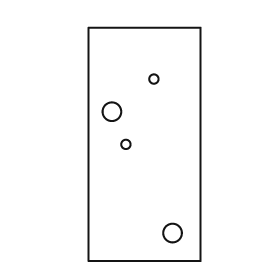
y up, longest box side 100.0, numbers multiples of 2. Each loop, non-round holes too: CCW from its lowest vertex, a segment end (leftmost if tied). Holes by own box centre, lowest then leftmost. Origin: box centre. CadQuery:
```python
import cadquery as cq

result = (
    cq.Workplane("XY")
    .moveTo(-24.0, -50.0)
    .lineTo(24.0, -50.0)
    .lineTo(24.0, 50.0)
    .lineTo(-24.0, 50.0)
    .close()
    .moveTo(12.0, -38.0)
    .circle(4.0)
    .moveTo(-8.0, 0.0)
    .circle(2.0)
    .moveTo(-14.0, 14.0)
    .circle(4.0)
    .moveTo(4.0, 28.0)
    .circle(2.0)
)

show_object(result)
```